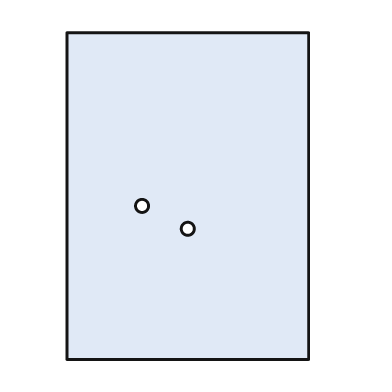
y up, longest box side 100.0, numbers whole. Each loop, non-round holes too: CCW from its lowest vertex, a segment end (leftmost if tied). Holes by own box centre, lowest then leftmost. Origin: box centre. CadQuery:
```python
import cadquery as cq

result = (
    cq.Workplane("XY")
    .moveTo(-37.0, -50.0)
    .lineTo(37.0, -50.0)
    .lineTo(37.0, 50.0)
    .lineTo(-37.0, 50.0)
    .close()
    .moveTo(0.0, -10.0)
    .circle(2.0)
    .moveTo(-14.0, -3.0)
    .circle(2.0)
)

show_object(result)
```